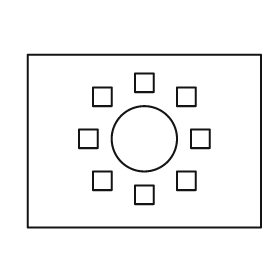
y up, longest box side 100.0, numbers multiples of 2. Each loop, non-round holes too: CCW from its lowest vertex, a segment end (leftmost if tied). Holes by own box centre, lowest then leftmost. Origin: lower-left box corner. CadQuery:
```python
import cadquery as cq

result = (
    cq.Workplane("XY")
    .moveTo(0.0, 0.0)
    .lineTo(100.0, 0.0)
    .lineTo(100.0, 74.0)
    .lineTo(0.0, 74.0)
    .close()
    .moveTo(46.0, 10.0)
    .lineTo(54.0, 10.0)
    .lineTo(54.0, 18.0)
    .lineTo(46.0, 18.0)
    .close()
    .moveTo(28.0, 16.0)
    .lineTo(36.0, 16.0)
    .lineTo(36.0, 24.0)
    .lineTo(28.0, 24.0)
    .close()
    .moveTo(64.0, 16.0)
    .lineTo(72.0, 16.0)
    .lineTo(72.0, 24.0)
    .lineTo(64.0, 24.0)
    .close()
    .moveTo(22.0, 34.0)
    .lineTo(30.0, 34.0)
    .lineTo(30.0, 42.0)
    .lineTo(22.0, 42.0)
    .close()
    .moveTo(50.0, 38.0)
    .circle(14.0)
    .moveTo(70.0, 34.0)
    .lineTo(78.0, 34.0)
    .lineTo(78.0, 42.0)
    .lineTo(70.0, 42.0)
    .close()
    .moveTo(28.0, 52.0)
    .lineTo(36.0, 52.0)
    .lineTo(36.0, 60.0)
    .lineTo(28.0, 60.0)
    .close()
    .moveTo(64.0, 52.0)
    .lineTo(72.0, 52.0)
    .lineTo(72.0, 60.0)
    .lineTo(64.0, 60.0)
    .close()
    .moveTo(46.0, 58.0)
    .lineTo(54.0, 58.0)
    .lineTo(54.0, 66.0)
    .lineTo(46.0, 66.0)
    .close()
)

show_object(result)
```